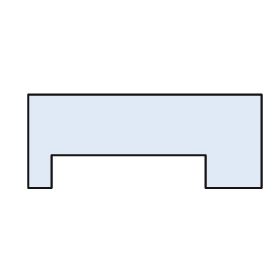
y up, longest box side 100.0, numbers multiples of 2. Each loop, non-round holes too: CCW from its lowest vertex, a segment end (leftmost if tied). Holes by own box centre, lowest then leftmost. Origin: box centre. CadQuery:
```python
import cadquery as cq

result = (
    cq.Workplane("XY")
    .moveTo(-50.0, -20.0)
    .lineTo(-40.0, -20.0)
    .lineTo(-40.0, -6.0)
    .lineTo(26.0, -6.0)
    .lineTo(26.0, -20.0)
    .lineTo(50.0, -20.0)
    .lineTo(50.0, 20.0)
    .lineTo(-50.0, 20.0)
    .close()
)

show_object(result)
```